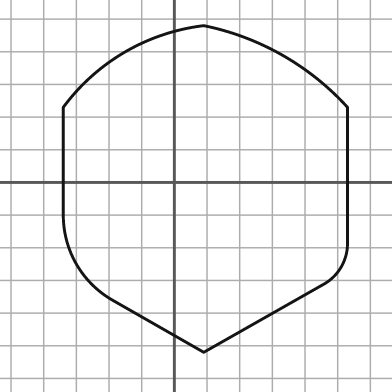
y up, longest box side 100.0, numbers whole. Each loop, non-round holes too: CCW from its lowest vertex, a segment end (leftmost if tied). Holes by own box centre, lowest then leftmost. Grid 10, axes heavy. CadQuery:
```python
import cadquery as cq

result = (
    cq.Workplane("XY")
    .moveTo(9.0, -52.0)
    .lineTo(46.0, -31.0)
    .threePointArc((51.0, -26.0), (53.0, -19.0))
    .lineTo(53.0, 23.0)
    .threePointArc((33.0, 39.0), (9.0, 48.0))
    .threePointArc((-15.0, 40.0), (-34.0, 23.0))
    .lineTo(-34.0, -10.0)
    .threePointArc((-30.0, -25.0), (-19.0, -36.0))
    .close()
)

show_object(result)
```